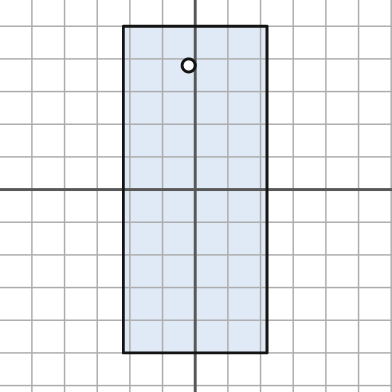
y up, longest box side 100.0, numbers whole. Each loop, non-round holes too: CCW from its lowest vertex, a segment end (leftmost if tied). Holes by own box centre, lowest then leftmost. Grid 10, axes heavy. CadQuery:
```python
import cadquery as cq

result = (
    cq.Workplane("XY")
    .moveTo(-22.0, -50.0)
    .lineTo(22.0, -50.0)
    .lineTo(22.0, 50.0)
    .lineTo(-22.0, 50.0)
    .close()
    .moveTo(-2.0, 38.0)
    .circle(2.0)
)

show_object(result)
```